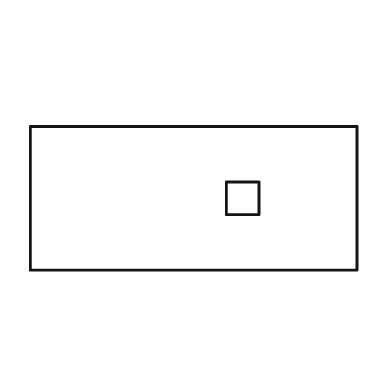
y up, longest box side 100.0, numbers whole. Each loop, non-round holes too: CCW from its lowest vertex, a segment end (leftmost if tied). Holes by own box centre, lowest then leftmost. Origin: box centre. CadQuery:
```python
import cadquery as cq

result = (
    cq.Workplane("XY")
    .moveTo(-50.0, -22.0)
    .lineTo(50.0, -22.0)
    .lineTo(50.0, 22.0)
    .lineTo(-50.0, 22.0)
    .close()
    .moveTo(10.0, -5.0)
    .lineTo(20.0, -5.0)
    .lineTo(20.0, 5.0)
    .lineTo(10.0, 5.0)
    .close()
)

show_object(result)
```